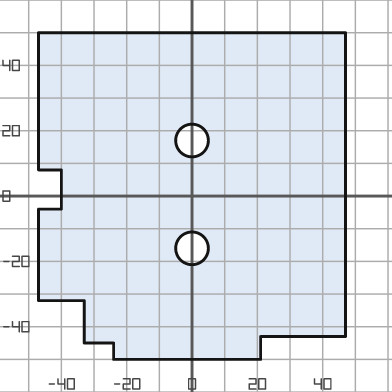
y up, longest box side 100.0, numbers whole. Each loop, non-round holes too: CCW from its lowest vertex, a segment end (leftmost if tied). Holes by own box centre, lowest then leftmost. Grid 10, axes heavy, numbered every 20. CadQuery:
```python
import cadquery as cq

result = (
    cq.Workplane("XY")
    .moveTo(-24.0, -50.0)
    .lineTo(21.0, -50.0)
    .lineTo(21.0, -43.0)
    .lineTo(47.0, -43.0)
    .lineTo(47.0, 50.0)
    .lineTo(-47.0, 50.0)
    .lineTo(-47.0, 8.0)
    .lineTo(-40.0, 8.0)
    .lineTo(-40.0, -4.0)
    .lineTo(-47.0, -4.0)
    .lineTo(-47.0, -32.0)
    .lineTo(-33.0, -32.0)
    .lineTo(-33.0, -45.0)
    .lineTo(-24.0, -45.0)
    .close()
    .moveTo(0.0, -16.0)
    .circle(5.0)
    .moveTo(0.0, 17.0)
    .circle(5.0)
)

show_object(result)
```